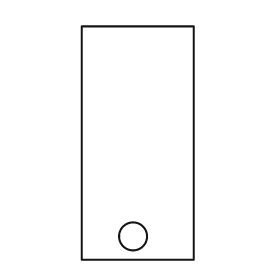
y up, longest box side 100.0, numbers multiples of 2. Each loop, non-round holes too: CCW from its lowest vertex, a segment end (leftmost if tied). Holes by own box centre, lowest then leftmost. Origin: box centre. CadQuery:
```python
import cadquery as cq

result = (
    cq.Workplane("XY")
    .moveTo(-24.0, -50.0)
    .lineTo(24.0, -50.0)
    .lineTo(24.0, 50.0)
    .lineTo(-24.0, 50.0)
    .close()
    .moveTo(-2.0, -40.0)
    .circle(6.0)
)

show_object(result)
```